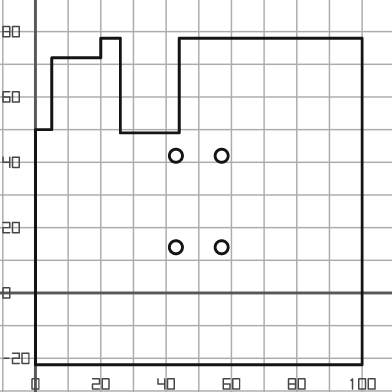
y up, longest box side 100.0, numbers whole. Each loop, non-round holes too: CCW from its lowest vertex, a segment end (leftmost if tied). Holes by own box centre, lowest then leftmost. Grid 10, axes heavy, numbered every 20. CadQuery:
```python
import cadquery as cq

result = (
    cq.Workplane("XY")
    .moveTo(0.0, -22.0)
    .lineTo(100.0, -22.0)
    .lineTo(100.0, 78.0)
    .lineTo(44.0, 78.0)
    .lineTo(44.0, 49.0)
    .lineTo(26.0, 49.0)
    .lineTo(26.0, 78.0)
    .lineTo(20.0, 78.0)
    .lineTo(20.0, 72.0)
    .lineTo(5.0, 72.0)
    .lineTo(5.0, 50.0)
    .lineTo(0.0, 50.0)
    .close()
    .moveTo(43.0, 14.0)
    .circle(2.0)
    .moveTo(57.0, 14.0)
    .circle(2.0)
    .moveTo(43.0, 42.0)
    .circle(2.0)
    .moveTo(57.0, 42.0)
    .circle(2.0)
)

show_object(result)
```